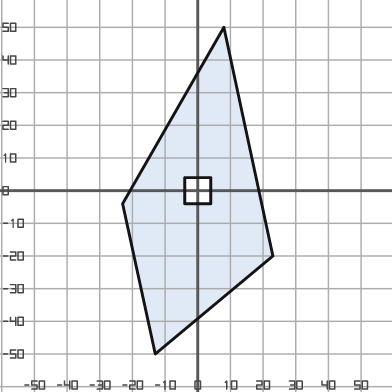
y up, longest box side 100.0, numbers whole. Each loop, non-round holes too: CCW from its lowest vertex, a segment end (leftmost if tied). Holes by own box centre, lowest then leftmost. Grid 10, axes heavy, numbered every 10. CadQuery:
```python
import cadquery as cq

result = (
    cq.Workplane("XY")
    .moveTo(-13.0, -50.0)
    .lineTo(23.0, -20.0)
    .lineTo(8.0, 50.0)
    .lineTo(-23.0, -4.0)
    .close()
    .moveTo(-4.0, -4.0)
    .lineTo(4.0, -4.0)
    .lineTo(4.0, 4.0)
    .lineTo(-4.0, 4.0)
    .close()
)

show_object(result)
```